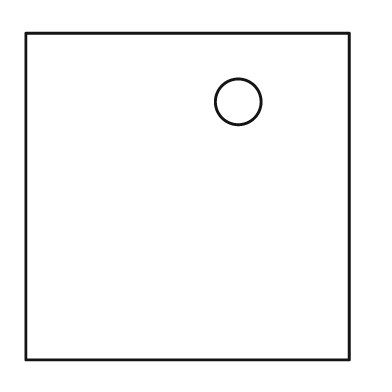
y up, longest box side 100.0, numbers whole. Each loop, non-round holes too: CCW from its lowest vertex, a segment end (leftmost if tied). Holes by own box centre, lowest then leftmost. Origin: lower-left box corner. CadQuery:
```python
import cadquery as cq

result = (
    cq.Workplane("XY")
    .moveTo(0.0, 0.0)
    .lineTo(99.0, 0.0)
    .lineTo(99.0, 100.0)
    .lineTo(0.0, 100.0)
    .close()
    .moveTo(65.0, 79.0)
    .circle(7.0)
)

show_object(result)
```